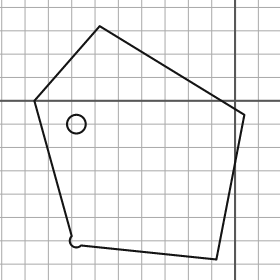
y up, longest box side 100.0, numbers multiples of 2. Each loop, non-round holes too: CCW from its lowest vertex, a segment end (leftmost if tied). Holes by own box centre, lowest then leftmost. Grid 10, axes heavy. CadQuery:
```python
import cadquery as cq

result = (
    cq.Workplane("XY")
    .moveTo(-8.0, -68.0)
    .lineTo(4.0, -6.0)
    .lineTo(-58.0, 32.0)
    .lineTo(-86.0, 0.0)
    .lineTo(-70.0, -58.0)
    .threePointArc((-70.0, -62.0), (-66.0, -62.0))
    .close()
    .moveTo(-68.0, -10.0)
    .circle(4.0)
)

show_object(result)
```